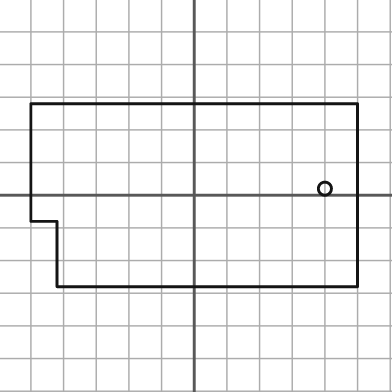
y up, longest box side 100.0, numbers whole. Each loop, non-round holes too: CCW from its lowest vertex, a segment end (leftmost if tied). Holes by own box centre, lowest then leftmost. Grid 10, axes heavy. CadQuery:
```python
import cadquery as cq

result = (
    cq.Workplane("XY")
    .moveTo(-42.0, -28.0)
    .lineTo(50.0, -28.0)
    .lineTo(50.0, 28.0)
    .lineTo(-50.0, 28.0)
    .lineTo(-50.0, -8.0)
    .lineTo(-42.0, -8.0)
    .close()
    .moveTo(40.0, 2.0)
    .circle(2.0)
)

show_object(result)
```